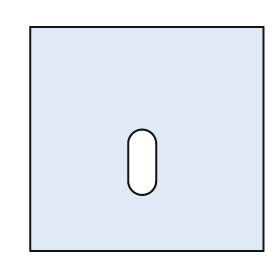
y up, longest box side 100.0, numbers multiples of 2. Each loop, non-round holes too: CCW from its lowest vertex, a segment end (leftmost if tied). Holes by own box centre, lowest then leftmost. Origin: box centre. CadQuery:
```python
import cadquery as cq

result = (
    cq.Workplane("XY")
    .moveTo(-50.0, -48.0)
    .lineTo(50.0, -48.0)
    .lineTo(50.0, 48.0)
    .lineTo(-50.0, 48.0)
    .close()
    .moveTo(-8.0, -18.0)
    .threePointArc((-2.0, -24.0), (4.0, -18.0))
    .lineTo(4.0, -2.0)
    .threePointArc((-2.0, 4.0), (-8.0, -2.0))
    .close()
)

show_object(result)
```